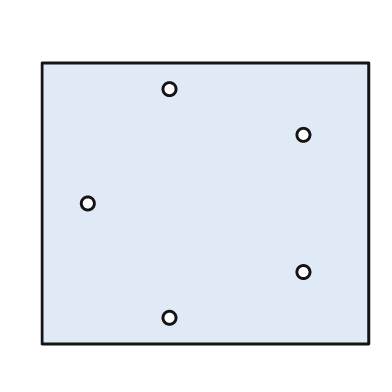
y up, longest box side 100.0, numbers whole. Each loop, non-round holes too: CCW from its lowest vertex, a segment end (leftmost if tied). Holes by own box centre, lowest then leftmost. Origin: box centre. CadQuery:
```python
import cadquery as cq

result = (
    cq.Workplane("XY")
    .moveTo(-50.0, -43.0)
    .lineTo(50.0, -43.0)
    .lineTo(50.0, 43.0)
    .lineTo(-50.0, 43.0)
    .close()
    .moveTo(-11.0, -35.0)
    .circle(2.0)
    .moveTo(30.0, -21.0)
    .circle(2.0)
    .moveTo(-36.0, 0.0)
    .circle(2.0)
    .moveTo(30.0, 21.0)
    .circle(2.0)
    .moveTo(-11.0, 35.0)
    .circle(2.0)
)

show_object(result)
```